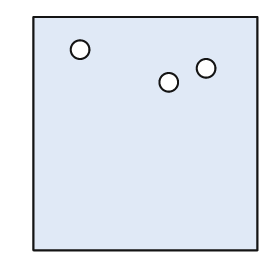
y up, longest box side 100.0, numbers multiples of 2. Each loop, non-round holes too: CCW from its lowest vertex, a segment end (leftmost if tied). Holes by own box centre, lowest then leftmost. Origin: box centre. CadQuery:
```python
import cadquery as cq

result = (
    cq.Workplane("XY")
    .moveTo(-48.0, -50.0)
    .lineTo(48.0, -50.0)
    .lineTo(48.0, 50.0)
    .lineTo(-48.0, 50.0)
    .close()
    .moveTo(10.0, 22.0)
    .circle(4.0)
    .moveTo(26.0, 28.0)
    .circle(4.0)
    .moveTo(-28.0, 36.0)
    .circle(4.0)
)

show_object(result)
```